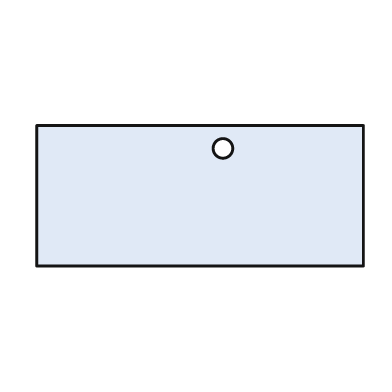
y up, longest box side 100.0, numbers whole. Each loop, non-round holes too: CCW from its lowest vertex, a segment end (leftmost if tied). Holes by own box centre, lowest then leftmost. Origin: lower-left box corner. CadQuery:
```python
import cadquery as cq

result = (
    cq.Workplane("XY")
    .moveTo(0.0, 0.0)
    .lineTo(100.0, 0.0)
    .lineTo(100.0, 43.0)
    .lineTo(0.0, 43.0)
    .close()
    .moveTo(57.0, 36.0)
    .circle(3.0)
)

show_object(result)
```